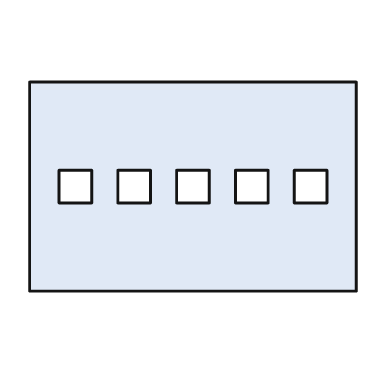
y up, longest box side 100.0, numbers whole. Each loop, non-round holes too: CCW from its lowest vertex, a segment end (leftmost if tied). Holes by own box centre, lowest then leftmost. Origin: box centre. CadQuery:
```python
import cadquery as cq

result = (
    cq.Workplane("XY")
    .moveTo(-50.0, -32.0)
    .lineTo(50.0, -32.0)
    .lineTo(50.0, 32.0)
    .lineTo(-50.0, 32.0)
    .close()
    .moveTo(-41.0, -5.0)
    .lineTo(-31.0, -5.0)
    .lineTo(-31.0, 5.0)
    .lineTo(-41.0, 5.0)
    .close()
    .moveTo(-23.0, -5.0)
    .lineTo(-13.0, -5.0)
    .lineTo(-13.0, 5.0)
    .lineTo(-23.0, 5.0)
    .close()
    .moveTo(-5.0, -5.0)
    .lineTo(5.0, -5.0)
    .lineTo(5.0, 5.0)
    .lineTo(-5.0, 5.0)
    .close()
    .moveTo(13.0, -5.0)
    .lineTo(23.0, -5.0)
    .lineTo(23.0, 5.0)
    .lineTo(13.0, 5.0)
    .close()
    .moveTo(31.0, -5.0)
    .lineTo(41.0, -5.0)
    .lineTo(41.0, 5.0)
    .lineTo(31.0, 5.0)
    .close()
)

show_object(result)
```